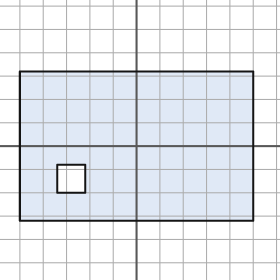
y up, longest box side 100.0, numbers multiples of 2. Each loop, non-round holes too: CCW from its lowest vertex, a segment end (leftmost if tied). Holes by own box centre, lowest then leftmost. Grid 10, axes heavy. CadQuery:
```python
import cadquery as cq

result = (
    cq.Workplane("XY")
    .moveTo(-50.0, -32.0)
    .lineTo(50.0, -32.0)
    .lineTo(50.0, 32.0)
    .lineTo(-50.0, 32.0)
    .close()
    .moveTo(-34.0, -20.0)
    .lineTo(-22.0, -20.0)
    .lineTo(-22.0, -8.0)
    .lineTo(-34.0, -8.0)
    .close()
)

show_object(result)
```